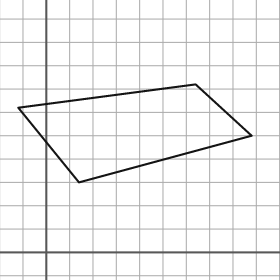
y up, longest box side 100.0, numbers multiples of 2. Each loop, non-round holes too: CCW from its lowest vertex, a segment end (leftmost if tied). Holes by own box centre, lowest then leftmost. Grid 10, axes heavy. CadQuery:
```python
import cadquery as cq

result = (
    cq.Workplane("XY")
    .moveTo(14.0, 30.0)
    .lineTo(88.0, 50.0)
    .lineTo(64.0, 72.0)
    .lineTo(-12.0, 62.0)
    .close()
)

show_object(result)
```